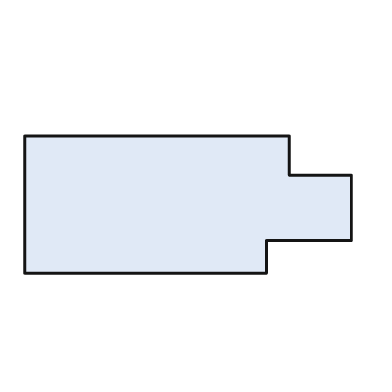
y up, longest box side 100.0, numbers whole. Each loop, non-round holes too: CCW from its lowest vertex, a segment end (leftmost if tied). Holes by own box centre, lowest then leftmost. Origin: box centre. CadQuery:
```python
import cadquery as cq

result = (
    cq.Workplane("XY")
    .moveTo(-50.0, -21.0)
    .lineTo(24.0, -21.0)
    .lineTo(24.0, -11.0)
    .lineTo(50.0, -11.0)
    .lineTo(50.0, 9.0)
    .lineTo(31.0, 9.0)
    .lineTo(31.0, 21.0)
    .lineTo(-50.0, 21.0)
    .close()
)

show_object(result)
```